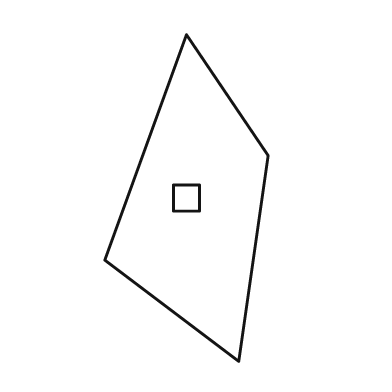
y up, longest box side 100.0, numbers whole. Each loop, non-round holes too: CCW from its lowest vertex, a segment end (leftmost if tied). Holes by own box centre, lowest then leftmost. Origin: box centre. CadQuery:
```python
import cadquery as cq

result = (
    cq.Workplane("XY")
    .moveTo(16.0, -50.0)
    .lineTo(25.0, 13.0)
    .lineTo(0.0, 50.0)
    .lineTo(-25.0, -19.0)
    .close()
    .moveTo(-4.0, -4.0)
    .lineTo(4.0, -4.0)
    .lineTo(4.0, 4.0)
    .lineTo(-4.0, 4.0)
    .close()
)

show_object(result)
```